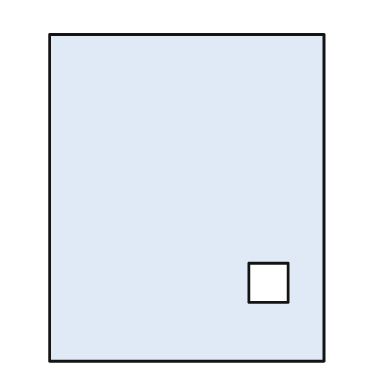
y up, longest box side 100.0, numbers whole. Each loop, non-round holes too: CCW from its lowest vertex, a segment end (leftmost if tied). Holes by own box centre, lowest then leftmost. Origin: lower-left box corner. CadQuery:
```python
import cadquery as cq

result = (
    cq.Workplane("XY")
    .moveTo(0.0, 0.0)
    .lineTo(84.0, 0.0)
    .lineTo(84.0, 100.0)
    .lineTo(0.0, 100.0)
    .close()
    .moveTo(61.0, 18.0)
    .lineTo(73.0, 18.0)
    .lineTo(73.0, 30.0)
    .lineTo(61.0, 30.0)
    .close()
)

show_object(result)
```